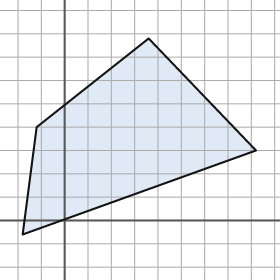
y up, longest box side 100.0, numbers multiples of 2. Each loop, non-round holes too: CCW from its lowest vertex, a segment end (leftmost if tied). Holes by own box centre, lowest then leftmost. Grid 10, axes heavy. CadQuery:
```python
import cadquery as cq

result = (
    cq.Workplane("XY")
    .moveTo(-18.0, -6.0)
    .lineTo(82.0, 30.0)
    .lineTo(36.0, 78.0)
    .lineTo(-12.0, 40.0)
    .close()
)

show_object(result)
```